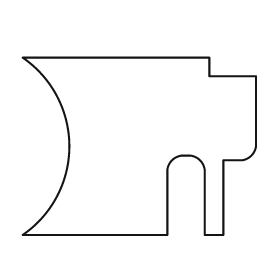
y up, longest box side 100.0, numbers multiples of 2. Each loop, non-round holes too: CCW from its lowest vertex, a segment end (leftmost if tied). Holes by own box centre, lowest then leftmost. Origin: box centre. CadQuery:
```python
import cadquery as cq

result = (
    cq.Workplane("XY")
    .moveTo(-50.0, -38.0)
    .lineTo(12.0, -38.0)
    .lineTo(12.0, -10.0)
    .threePointArc((14.0, -6.0), (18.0, -4.0))
    .lineTo(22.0, -4.0)
    .threePointArc((26.0, -6.0), (28.0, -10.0))
    .lineTo(28.0, -38.0)
    .lineTo(36.0, -38.0)
    .lineTo(36.0, -6.0)
    .lineTo(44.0, -6.0)
    .threePointArc((48.0, -4.0), (50.0, 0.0))
    .lineTo(50.0, 30.0)
    .lineTo(30.0, 30.0)
    .lineTo(30.0, 38.0)
    .lineTo(-50.0, 38.0)
    .threePointArc((-30.0, 0.0), (-50.0, -38.0))
    .close()
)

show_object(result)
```